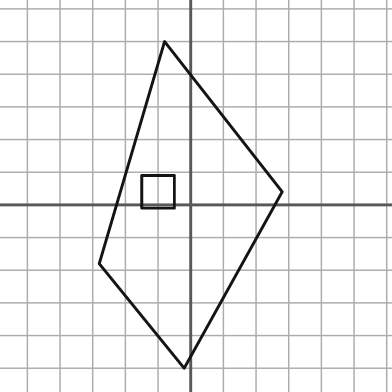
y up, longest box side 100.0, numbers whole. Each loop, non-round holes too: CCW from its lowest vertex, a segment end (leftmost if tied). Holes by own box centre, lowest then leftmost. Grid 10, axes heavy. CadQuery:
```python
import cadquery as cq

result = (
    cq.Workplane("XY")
    .moveTo(-2.0, -50.0)
    .lineTo(28.0, 4.0)
    .lineTo(-8.0, 50.0)
    .lineTo(-28.0, -18.0)
    .close()
    .moveTo(-15.0, -1.0)
    .lineTo(-5.0, -1.0)
    .lineTo(-5.0, 9.0)
    .lineTo(-15.0, 9.0)
    .close()
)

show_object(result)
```